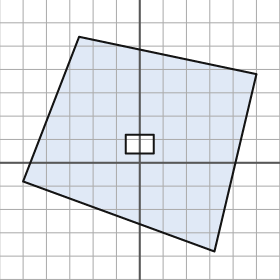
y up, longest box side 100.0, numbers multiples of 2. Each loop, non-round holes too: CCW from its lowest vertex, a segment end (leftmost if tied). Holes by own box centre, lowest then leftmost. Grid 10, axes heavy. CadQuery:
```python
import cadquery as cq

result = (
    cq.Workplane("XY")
    .moveTo(32.0, -38.0)
    .lineTo(50.0, 38.0)
    .lineTo(-26.0, 54.0)
    .lineTo(-50.0, -8.0)
    .close()
    .moveTo(-6.0, 4.0)
    .lineTo(6.0, 4.0)
    .lineTo(6.0, 12.0)
    .lineTo(-6.0, 12.0)
    .close()
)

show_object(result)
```